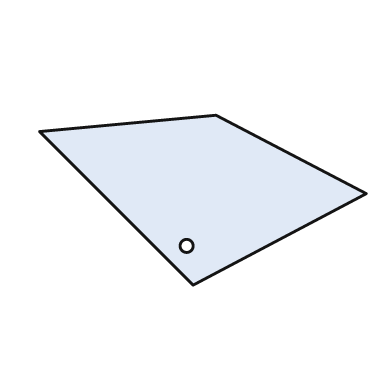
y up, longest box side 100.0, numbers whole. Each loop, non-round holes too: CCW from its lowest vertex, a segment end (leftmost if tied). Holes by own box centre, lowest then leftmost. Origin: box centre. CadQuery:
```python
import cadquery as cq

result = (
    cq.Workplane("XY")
    .moveTo(-3.0, -26.0)
    .lineTo(50.0, 2.0)
    .lineTo(4.0, 26.0)
    .lineTo(-50.0, 21.0)
    .close()
    .moveTo(-5.0, -14.0)
    .circle(2.0)
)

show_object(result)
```